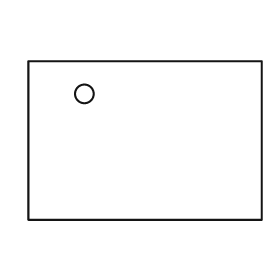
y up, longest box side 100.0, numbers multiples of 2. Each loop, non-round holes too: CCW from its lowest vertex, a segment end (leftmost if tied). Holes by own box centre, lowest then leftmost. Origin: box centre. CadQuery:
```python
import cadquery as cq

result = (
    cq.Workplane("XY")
    .moveTo(-50.0, -34.0)
    .lineTo(50.0, -34.0)
    .lineTo(50.0, 34.0)
    .lineTo(-50.0, 34.0)
    .close()
    .moveTo(-26.0, 20.0)
    .circle(4.0)
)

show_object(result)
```